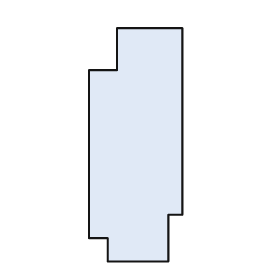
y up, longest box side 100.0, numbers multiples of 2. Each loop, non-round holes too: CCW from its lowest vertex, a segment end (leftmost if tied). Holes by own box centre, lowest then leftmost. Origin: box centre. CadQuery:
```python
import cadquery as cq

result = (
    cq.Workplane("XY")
    .moveTo(-12.0, -50.0)
    .lineTo(14.0, -50.0)
    .lineTo(14.0, -30.0)
    .lineTo(20.0, -30.0)
    .lineTo(20.0, 50.0)
    .lineTo(-8.0, 50.0)
    .lineTo(-8.0, 32.0)
    .lineTo(-20.0, 32.0)
    .lineTo(-20.0, -40.0)
    .lineTo(-12.0, -40.0)
    .close()
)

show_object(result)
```